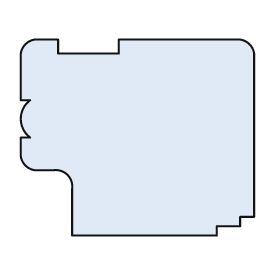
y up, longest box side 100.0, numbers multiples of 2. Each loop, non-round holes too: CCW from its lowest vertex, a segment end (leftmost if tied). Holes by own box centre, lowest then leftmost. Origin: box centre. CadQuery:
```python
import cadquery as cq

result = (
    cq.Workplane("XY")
    .moveTo(-28.0, -42.0)
    .lineTo(34.0, -42.0)
    .lineTo(34.0, -38.0)
    .lineTo(44.0, -38.0)
    .lineTo(44.0, -34.0)
    .lineTo(50.0, -34.0)
    .lineTo(50.0, 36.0)
    .threePointArc((48.0, 40.0), (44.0, 42.0))
    .lineTo(-8.0, 42.0)
    .lineTo(-8.0, 36.0)
    .lineTo(-34.0, 36.0)
    .lineTo(-34.0, 42.0)
    .lineTo(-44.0, 42.0)
    .threePointArc((-48.0, 40.0), (-50.0, 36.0))
    .lineTo(-50.0, 16.0)
    .lineTo(-46.0, 16.0)
    .threePointArc((-50.0, 8.0), (-46.0, 0.0))
    .lineTo(-50.0, 0.0)
    .lineTo(-50.0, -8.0)
    .threePointArc((-48.0, -12.0), (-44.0, -14.0))
    .lineTo(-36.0, -14.0)
    .threePointArc((-30.0, -16.0), (-28.0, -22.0))
    .close()
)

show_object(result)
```